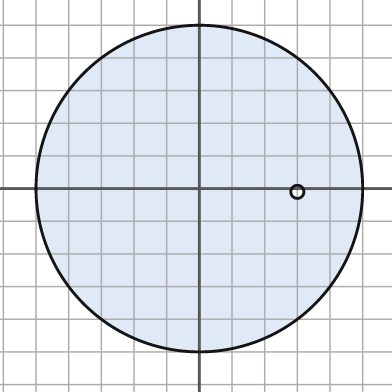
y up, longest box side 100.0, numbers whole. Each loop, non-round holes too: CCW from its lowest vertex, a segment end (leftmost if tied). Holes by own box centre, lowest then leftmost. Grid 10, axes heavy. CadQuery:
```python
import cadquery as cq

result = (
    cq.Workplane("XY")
    .moveTo(0.0, 0.0)
    .circle(50.0)
    .moveTo(30.0, -1.0)
    .circle(2.0)
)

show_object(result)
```